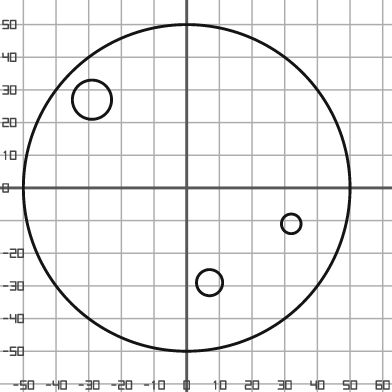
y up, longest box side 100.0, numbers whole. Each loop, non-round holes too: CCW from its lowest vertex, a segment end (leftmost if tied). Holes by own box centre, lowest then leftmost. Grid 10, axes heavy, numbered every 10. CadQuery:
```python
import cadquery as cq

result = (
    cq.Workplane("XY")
    .moveTo(0.0, 0.0)
    .circle(50.0)
    .moveTo(7.0, -29.0)
    .circle(4.0)
    .moveTo(32.0, -11.0)
    .circle(3.0)
    .moveTo(-29.0, 27.0)
    .circle(6.0)
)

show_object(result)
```